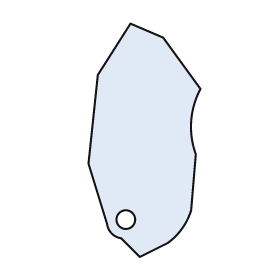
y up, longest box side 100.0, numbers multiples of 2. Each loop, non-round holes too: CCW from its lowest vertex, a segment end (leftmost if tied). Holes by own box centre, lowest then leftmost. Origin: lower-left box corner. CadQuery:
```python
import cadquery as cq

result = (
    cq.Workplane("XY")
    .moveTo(22.0, 0.0)
    .lineTo(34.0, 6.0)
    .threePointArc((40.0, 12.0), (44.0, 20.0))
    .lineTo(46.0, 44.0)
    .threePointArc((44.0, 58.0), (48.0, 72.0))
    .lineTo(32.0, 94.0)
    .lineTo(18.0, 100.0)
    .lineTo(4.0, 78.0)
    .lineTo(0.0, 40.0)
    .lineTo(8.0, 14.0)
    .threePointArc((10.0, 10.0), (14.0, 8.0))
    .close()
    .moveTo(16.0, 16.0)
    .circle(4.0)
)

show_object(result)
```